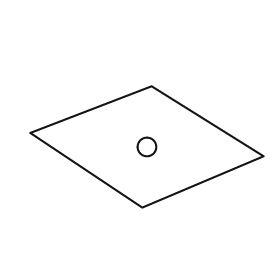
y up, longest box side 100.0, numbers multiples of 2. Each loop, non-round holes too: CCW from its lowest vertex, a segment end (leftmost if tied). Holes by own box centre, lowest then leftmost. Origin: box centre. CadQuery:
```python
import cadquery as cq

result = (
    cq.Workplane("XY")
    .moveTo(-2.0, -26.0)
    .lineTo(50.0, -4.0)
    .lineTo(2.0, 26.0)
    .lineTo(-50.0, 6.0)
    .close()
    .moveTo(0.0, 0.0)
    .circle(4.0)
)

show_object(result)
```